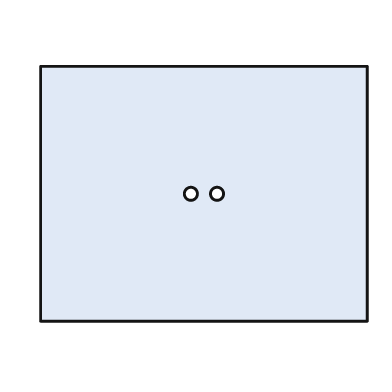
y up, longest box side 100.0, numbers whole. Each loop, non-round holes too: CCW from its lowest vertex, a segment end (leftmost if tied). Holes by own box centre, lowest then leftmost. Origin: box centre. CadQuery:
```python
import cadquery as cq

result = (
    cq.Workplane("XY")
    .moveTo(-50.0, -39.0)
    .lineTo(50.0, -39.0)
    .lineTo(50.0, 39.0)
    .lineTo(-50.0, 39.0)
    .close()
    .moveTo(-4.0, 0.0)
    .circle(2.0)
    .moveTo(4.0, 0.0)
    .circle(2.0)
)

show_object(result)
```